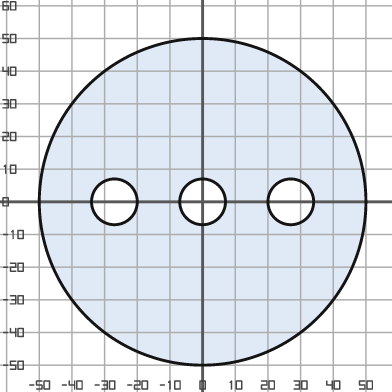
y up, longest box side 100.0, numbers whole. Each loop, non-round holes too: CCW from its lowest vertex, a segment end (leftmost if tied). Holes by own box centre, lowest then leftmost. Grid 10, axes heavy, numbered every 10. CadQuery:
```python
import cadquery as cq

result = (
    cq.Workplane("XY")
    .moveTo(0.0, 0.0)
    .circle(50.0)
    .moveTo(-27.0, 0.0)
    .circle(7.0)
    .moveTo(0.0, 0.0)
    .circle(7.0)
    .moveTo(27.0, 0.0)
    .circle(7.0)
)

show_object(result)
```